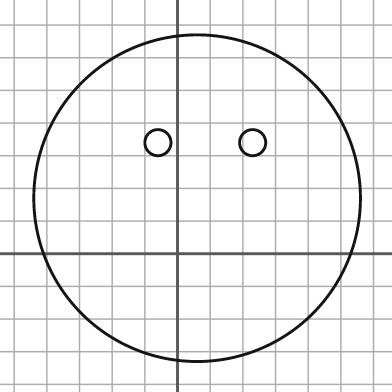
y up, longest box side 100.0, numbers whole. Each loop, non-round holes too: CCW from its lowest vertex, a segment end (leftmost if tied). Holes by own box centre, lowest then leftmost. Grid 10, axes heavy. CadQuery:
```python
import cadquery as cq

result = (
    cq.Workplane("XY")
    .moveTo(6.0, 17.0)
    .circle(50.0)
    .moveTo(-6.0, 34.0)
    .circle(4.0)
    .moveTo(23.0, 34.0)
    .circle(4.0)
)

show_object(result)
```